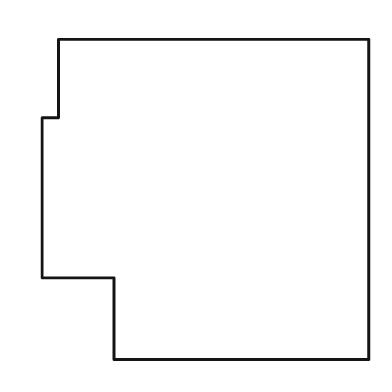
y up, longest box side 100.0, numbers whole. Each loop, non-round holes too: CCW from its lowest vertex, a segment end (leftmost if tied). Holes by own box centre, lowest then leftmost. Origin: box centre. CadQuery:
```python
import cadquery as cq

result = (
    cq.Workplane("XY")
    .moveTo(-28.0, -49.0)
    .lineTo(50.0, -49.0)
    .lineTo(50.0, 49.0)
    .lineTo(-45.0, 49.0)
    .lineTo(-45.0, 25.0)
    .lineTo(-50.0, 25.0)
    .lineTo(-50.0, -24.0)
    .lineTo(-28.0, -24.0)
    .close()
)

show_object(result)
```